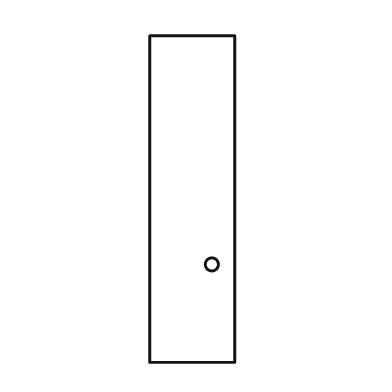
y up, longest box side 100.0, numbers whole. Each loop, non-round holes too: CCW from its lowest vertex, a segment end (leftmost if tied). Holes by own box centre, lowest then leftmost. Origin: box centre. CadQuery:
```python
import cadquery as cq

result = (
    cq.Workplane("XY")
    .moveTo(-13.0, -50.0)
    .lineTo(13.0, -50.0)
    .lineTo(13.0, 50.0)
    .lineTo(-13.0, 50.0)
    .close()
    .moveTo(6.0, -20.0)
    .circle(2.0)
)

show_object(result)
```